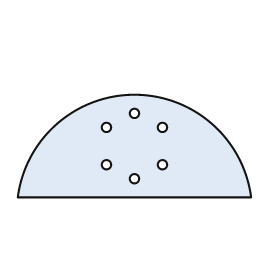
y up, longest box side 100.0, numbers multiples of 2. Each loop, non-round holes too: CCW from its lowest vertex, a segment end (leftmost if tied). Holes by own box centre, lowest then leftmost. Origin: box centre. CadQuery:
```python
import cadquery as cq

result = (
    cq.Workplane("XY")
    .moveTo(-50.0, -22.0)
    .lineTo(50.0, -22.0)
    .threePointArc((0.0, 22.0), (-50.0, -22.0))
    .close()
    .moveTo(0.0, -14.0)
    .circle(2.0)
    .moveTo(-12.0, -8.0)
    .circle(2.0)
    .moveTo(12.0, -8.0)
    .circle(2.0)
    .moveTo(-12.0, 8.0)
    .circle(2.0)
    .moveTo(12.0, 8.0)
    .circle(2.0)
    .moveTo(0.0, 14.0)
    .circle(2.0)
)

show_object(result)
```